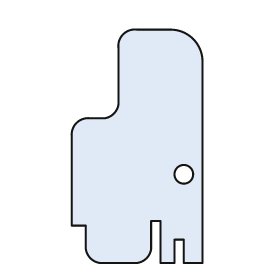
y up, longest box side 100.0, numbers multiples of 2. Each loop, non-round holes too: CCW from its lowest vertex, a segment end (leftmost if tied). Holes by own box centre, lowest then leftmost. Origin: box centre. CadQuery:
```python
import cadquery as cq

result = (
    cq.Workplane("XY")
    .moveTo(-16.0, -50.0)
    .lineTo(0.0, -50.0)
    .threePointArc((4.0, -48.0), (6.0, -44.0))
    .lineTo(6.0, -32.0)
    .lineTo(10.0, -32.0)
    .lineTo(10.0, -50.0)
    .lineTo(16.0, -50.0)
    .lineTo(16.0, -40.0)
    .lineTo(20.0, -40.0)
    .lineTo(20.0, -50.0)
    .lineTo(28.0, -50.0)
    .lineTo(28.0, 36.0)
    .threePointArc((24.0, 46.0), (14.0, 50.0))
    .lineTo(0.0, 50.0)
    .threePointArc((-6.0, 48.0), (-8.0, 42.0))
    .lineTo(-8.0, 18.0)
    .threePointArc((-10.0, 14.0), (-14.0, 12.0))
    .lineTo(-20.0, 12.0)
    .threePointArc((-26.0, 10.0), (-28.0, 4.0))
    .lineTo(-28.0, -34.0)
    .lineTo(-22.0, -34.0)
    .lineTo(-22.0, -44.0)
    .threePointArc((-20.0, -48.0), (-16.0, -50.0))
    .close()
    .moveTo(20.0, -12.0)
    .circle(4.0)
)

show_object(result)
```